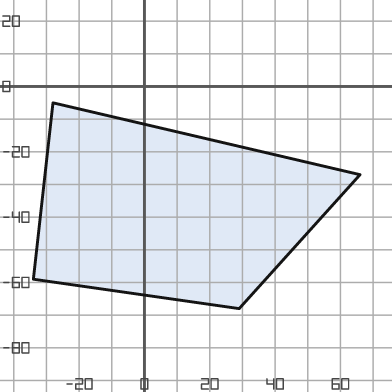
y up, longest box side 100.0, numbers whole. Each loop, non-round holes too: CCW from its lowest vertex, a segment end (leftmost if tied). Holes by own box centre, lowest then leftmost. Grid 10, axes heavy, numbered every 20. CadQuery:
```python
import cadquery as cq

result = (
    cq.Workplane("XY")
    .moveTo(29.0, -68.0)
    .lineTo(66.0, -27.0)
    .lineTo(-28.0, -5.0)
    .lineTo(-34.0, -59.0)
    .close()
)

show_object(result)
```